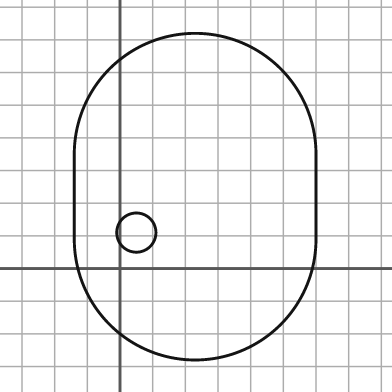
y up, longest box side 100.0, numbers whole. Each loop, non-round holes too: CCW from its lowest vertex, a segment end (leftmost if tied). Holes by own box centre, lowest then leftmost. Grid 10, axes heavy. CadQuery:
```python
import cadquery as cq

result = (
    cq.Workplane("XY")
    .moveTo(-14.0, 9.0)
    .threePointArc((23.0, -28.0), (60.0, 9.0))
    .lineTo(60.0, 35.0)
    .threePointArc((23.0, 72.0), (-14.0, 35.0))
    .close()
    .moveTo(5.0, 11.0)
    .circle(6.0)
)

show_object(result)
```